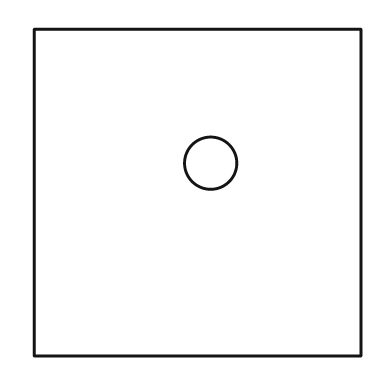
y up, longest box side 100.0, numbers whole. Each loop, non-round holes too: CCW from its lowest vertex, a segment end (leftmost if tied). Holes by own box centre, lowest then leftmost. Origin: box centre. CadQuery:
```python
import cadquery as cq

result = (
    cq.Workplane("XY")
    .moveTo(-50.0, -50.0)
    .lineTo(50.0, -50.0)
    .lineTo(50.0, 50.0)
    .lineTo(-50.0, 50.0)
    .close()
    .moveTo(4.0, 9.0)
    .circle(8.0)
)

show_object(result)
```